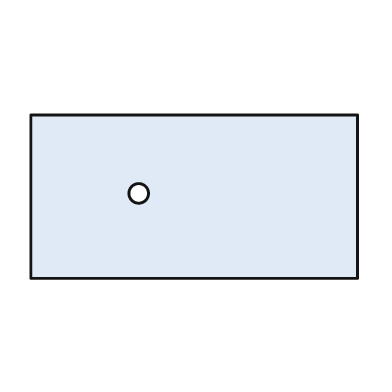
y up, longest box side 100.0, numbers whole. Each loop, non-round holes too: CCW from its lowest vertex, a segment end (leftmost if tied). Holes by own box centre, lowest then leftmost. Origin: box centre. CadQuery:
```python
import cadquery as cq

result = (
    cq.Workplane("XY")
    .moveTo(-50.0, -25.0)
    .lineTo(50.0, -25.0)
    .lineTo(50.0, 25.0)
    .lineTo(-50.0, 25.0)
    .close()
    .moveTo(-17.0, 1.0)
    .circle(3.0)
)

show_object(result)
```